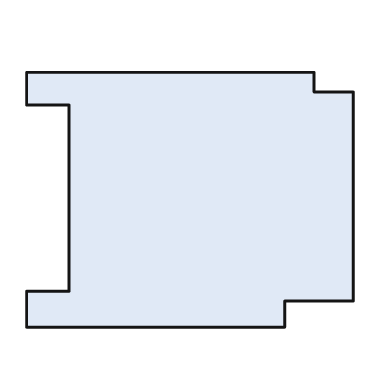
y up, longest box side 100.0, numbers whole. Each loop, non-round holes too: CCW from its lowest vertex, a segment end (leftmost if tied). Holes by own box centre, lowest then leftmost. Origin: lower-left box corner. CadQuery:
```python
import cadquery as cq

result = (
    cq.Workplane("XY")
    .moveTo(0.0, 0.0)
    .lineTo(79.0, 0.0)
    .lineTo(79.0, 8.0)
    .lineTo(100.0, 8.0)
    .lineTo(100.0, 72.0)
    .lineTo(88.0, 72.0)
    .lineTo(88.0, 78.0)
    .lineTo(0.0, 78.0)
    .lineTo(0.0, 68.0)
    .lineTo(13.0, 68.0)
    .lineTo(13.0, 11.0)
    .lineTo(0.0, 11.0)
    .close()
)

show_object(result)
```